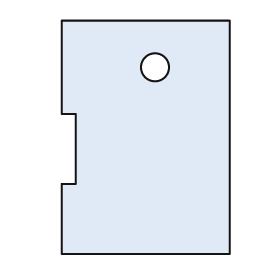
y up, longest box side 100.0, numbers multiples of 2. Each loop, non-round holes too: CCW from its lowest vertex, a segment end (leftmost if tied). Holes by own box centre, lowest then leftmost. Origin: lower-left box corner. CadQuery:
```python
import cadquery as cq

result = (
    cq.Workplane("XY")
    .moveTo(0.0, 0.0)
    .lineTo(72.0, 0.0)
    .lineTo(72.0, 100.0)
    .lineTo(0.0, 100.0)
    .lineTo(0.0, 60.0)
    .lineTo(6.0, 60.0)
    .lineTo(6.0, 30.0)
    .lineTo(0.0, 30.0)
    .close()
    .moveTo(40.0, 80.0)
    .circle(6.0)
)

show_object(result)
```